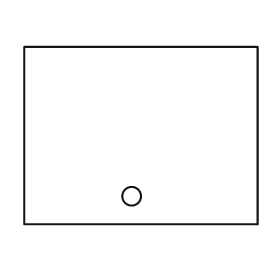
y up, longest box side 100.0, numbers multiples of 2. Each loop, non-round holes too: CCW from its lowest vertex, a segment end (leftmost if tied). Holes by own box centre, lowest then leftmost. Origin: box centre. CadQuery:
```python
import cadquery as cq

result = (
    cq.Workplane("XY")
    .moveTo(-50.0, -38.0)
    .lineTo(50.0, -38.0)
    .lineTo(50.0, 38.0)
    .lineTo(-50.0, 38.0)
    .close()
    .moveTo(-4.0, -26.0)
    .circle(4.0)
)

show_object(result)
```